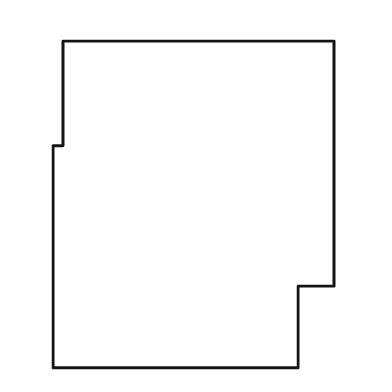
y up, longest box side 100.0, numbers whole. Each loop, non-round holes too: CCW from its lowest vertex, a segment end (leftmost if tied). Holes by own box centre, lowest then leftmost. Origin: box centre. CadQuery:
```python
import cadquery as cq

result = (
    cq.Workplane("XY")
    .moveTo(-43.0, -50.0)
    .lineTo(32.0, -50.0)
    .lineTo(32.0, -25.0)
    .lineTo(43.0, -25.0)
    .lineTo(43.0, 50.0)
    .lineTo(-40.0, 50.0)
    .lineTo(-40.0, 18.0)
    .lineTo(-43.0, 18.0)
    .close()
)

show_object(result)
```